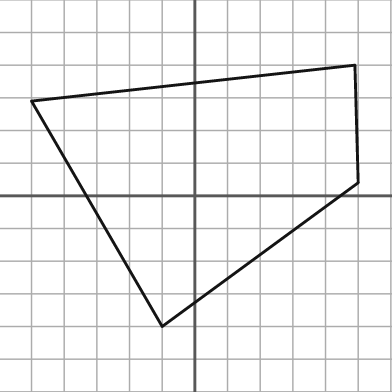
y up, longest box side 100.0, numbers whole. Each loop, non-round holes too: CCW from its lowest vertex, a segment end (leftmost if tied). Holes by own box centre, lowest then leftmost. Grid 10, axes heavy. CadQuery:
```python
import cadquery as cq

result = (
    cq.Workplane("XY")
    .moveTo(-10.0, -40.0)
    .lineTo(50.0, 4.0)
    .lineTo(49.0, 40.0)
    .lineTo(-50.0, 29.0)
    .close()
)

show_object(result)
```